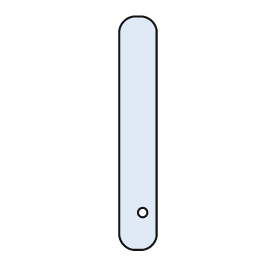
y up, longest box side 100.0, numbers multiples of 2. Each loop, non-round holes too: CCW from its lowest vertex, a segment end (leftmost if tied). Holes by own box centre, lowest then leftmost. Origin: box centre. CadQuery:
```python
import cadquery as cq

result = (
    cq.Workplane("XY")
    .moveTo(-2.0, -50.0)
    .lineTo(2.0, -50.0)
    .threePointArc((6.0, -48.0), (8.0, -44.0))
    .lineTo(8.0, 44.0)
    .threePointArc((6.0, 48.0), (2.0, 50.0))
    .lineTo(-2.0, 50.0)
    .threePointArc((-6.0, 48.0), (-8.0, 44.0))
    .lineTo(-8.0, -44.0)
    .threePointArc((-6.0, -48.0), (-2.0, -50.0))
    .close()
    .moveTo(2.0, -34.0)
    .circle(2.0)
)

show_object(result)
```